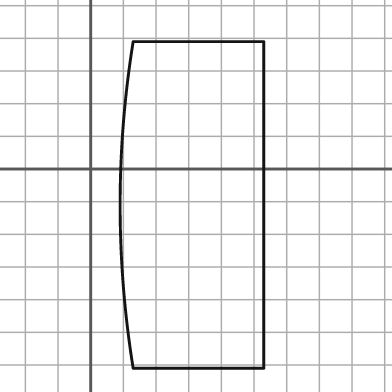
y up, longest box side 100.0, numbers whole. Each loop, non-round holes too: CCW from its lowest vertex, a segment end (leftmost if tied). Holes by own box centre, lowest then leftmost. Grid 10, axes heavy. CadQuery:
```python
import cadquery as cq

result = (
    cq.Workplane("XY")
    .moveTo(13.0, -61.0)
    .lineTo(53.0, -61.0)
    .lineTo(53.0, 39.0)
    .lineTo(13.0, 39.0)
    .threePointArc((9.0, -11.0), (13.0, -61.0))
    .close()
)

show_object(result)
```